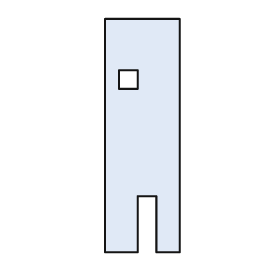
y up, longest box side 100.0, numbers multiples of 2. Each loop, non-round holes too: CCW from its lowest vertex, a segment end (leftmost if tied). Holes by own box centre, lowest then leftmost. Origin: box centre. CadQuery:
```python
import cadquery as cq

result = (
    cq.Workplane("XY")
    .moveTo(-16.0, -50.0)
    .lineTo(-2.0, -50.0)
    .lineTo(-2.0, -26.0)
    .lineTo(6.0, -26.0)
    .lineTo(6.0, -50.0)
    .lineTo(16.0, -50.0)
    .lineTo(16.0, 50.0)
    .lineTo(-16.0, 50.0)
    .close()
    .moveTo(-10.0, 20.0)
    .lineTo(-2.0, 20.0)
    .lineTo(-2.0, 28.0)
    .lineTo(-10.0, 28.0)
    .close()
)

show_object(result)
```